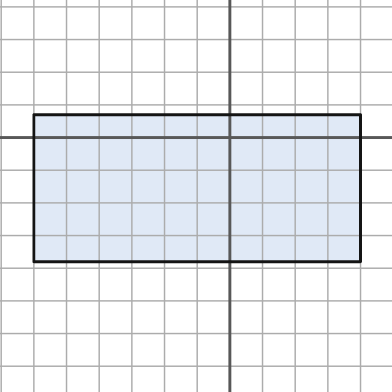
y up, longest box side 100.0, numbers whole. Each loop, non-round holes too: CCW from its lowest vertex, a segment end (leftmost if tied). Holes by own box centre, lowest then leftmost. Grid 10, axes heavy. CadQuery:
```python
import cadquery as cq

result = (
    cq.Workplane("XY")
    .moveTo(-60.0, -38.0)
    .lineTo(40.0, -38.0)
    .lineTo(40.0, 7.0)
    .lineTo(-60.0, 7.0)
    .close()
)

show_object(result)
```